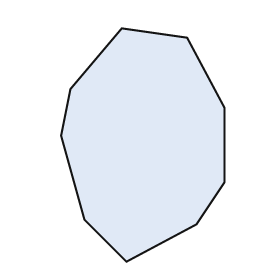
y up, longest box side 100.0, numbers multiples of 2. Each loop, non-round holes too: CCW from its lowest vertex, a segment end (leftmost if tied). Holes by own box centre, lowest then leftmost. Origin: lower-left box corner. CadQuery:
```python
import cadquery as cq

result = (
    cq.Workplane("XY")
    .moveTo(28.0, 0.0)
    .lineTo(58.0, 16.0)
    .lineTo(70.0, 34.0)
    .lineTo(70.0, 66.0)
    .lineTo(54.0, 96.0)
    .lineTo(26.0, 100.0)
    .lineTo(4.0, 74.0)
    .lineTo(0.0, 54.0)
    .lineTo(10.0, 18.0)
    .close()
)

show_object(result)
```